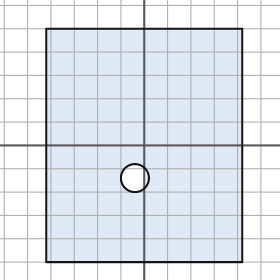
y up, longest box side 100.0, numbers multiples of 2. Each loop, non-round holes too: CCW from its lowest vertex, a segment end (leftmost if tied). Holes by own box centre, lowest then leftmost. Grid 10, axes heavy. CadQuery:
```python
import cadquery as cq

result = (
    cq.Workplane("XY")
    .moveTo(-42.0, -50.0)
    .lineTo(42.0, -50.0)
    .lineTo(42.0, 50.0)
    .lineTo(-42.0, 50.0)
    .close()
    .moveTo(-4.0, -14.0)
    .circle(6.0)
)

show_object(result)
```